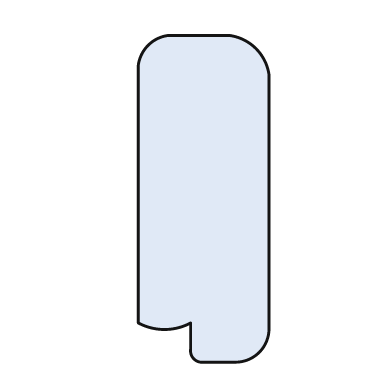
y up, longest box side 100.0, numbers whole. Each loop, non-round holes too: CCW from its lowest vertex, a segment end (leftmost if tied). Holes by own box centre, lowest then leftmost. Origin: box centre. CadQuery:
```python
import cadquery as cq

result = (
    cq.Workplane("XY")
    .moveTo(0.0, -50.0)
    .lineTo(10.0, -50.0)
    .threePointArc((17.0, -47.0), (20.0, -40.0))
    .lineTo(20.0, 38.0)
    .threePointArc((16.0, 46.0), (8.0, 50.0))
    .lineTo(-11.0, 50.0)
    .threePointArc((-17.0, 47.0), (-20.0, 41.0))
    .lineTo(-20.0, -38.0)
    .threePointArc((-12.0, -40.0), (-4.0, -38.0))
    .lineTo(-4.0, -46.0)
    .threePointArc((-3.0, -49.0), (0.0, -50.0))
    .close()
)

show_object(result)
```